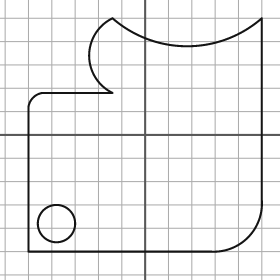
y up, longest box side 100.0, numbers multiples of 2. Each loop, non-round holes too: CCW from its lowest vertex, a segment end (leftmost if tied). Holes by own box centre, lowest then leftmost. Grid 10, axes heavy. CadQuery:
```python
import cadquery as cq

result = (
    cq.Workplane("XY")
    .moveTo(-50.0, -50.0)
    .lineTo(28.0, -50.0)
    .threePointArc((44.0, -44.0), (50.0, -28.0))
    .lineTo(50.0, 50.0)
    .threePointArc((18.0, 38.0), (-14.0, 50.0))
    .threePointArc((-24.0, 34.0), (-14.0, 18.0))
    .lineTo(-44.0, 18.0)
    .threePointArc((-48.0, 16.0), (-50.0, 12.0))
    .close()
    .moveTo(-38.0, -38.0)
    .circle(8.0)
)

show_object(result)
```